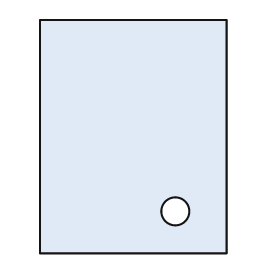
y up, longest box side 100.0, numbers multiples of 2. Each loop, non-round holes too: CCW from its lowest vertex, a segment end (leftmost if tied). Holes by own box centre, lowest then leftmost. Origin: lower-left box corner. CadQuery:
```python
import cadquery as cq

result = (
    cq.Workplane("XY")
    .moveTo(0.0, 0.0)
    .lineTo(80.0, 0.0)
    .lineTo(80.0, 100.0)
    .lineTo(0.0, 100.0)
    .close()
    .moveTo(58.0, 18.0)
    .circle(6.0)
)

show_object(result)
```